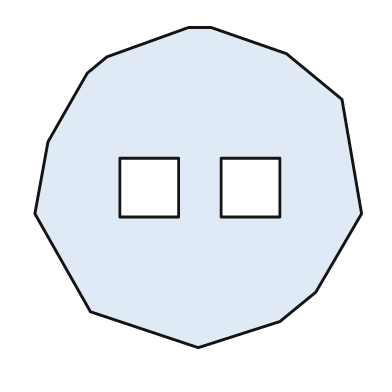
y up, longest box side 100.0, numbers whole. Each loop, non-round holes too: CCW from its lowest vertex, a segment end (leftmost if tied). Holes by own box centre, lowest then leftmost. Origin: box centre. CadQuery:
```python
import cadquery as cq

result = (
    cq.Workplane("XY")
    .moveTo(0.0, -49.0)
    .lineTo(25.0, -41.0)
    .lineTo(36.0, -32.0)
    .lineTo(50.0, -8.0)
    .lineTo(44.0, 27.0)
    .lineTo(27.0, 41.0)
    .lineTo(4.0, 49.0)
    .lineTo(-3.0, 49.0)
    .lineTo(-28.0, 40.0)
    .lineTo(-34.0, 35.0)
    .lineTo(-46.0, 14.0)
    .lineTo(-50.0, -8.0)
    .lineTo(-33.0, -38.0)
    .close()
    .moveTo(-24.0, -9.0)
    .lineTo(-6.0, -9.0)
    .lineTo(-6.0, 9.0)
    .lineTo(-24.0, 9.0)
    .close()
    .moveTo(7.0, -9.0)
    .lineTo(25.0, -9.0)
    .lineTo(25.0, 9.0)
    .lineTo(7.0, 9.0)
    .close()
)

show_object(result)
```